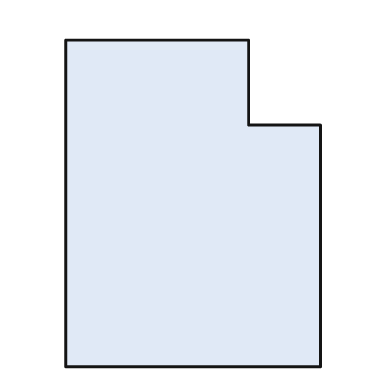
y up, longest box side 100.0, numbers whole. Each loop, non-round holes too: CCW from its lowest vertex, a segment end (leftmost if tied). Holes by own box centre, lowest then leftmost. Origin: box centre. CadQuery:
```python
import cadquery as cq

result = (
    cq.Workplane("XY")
    .moveTo(-39.0, -50.0)
    .lineTo(39.0, -50.0)
    .lineTo(39.0, 24.0)
    .lineTo(17.0, 24.0)
    .lineTo(17.0, 50.0)
    .lineTo(-39.0, 50.0)
    .close()
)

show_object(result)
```